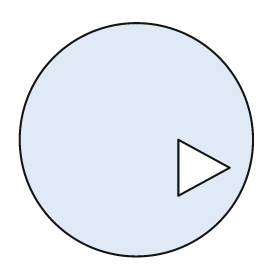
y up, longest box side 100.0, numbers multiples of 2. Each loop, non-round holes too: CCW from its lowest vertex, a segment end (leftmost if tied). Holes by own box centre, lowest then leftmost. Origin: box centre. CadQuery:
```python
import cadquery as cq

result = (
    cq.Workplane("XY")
    .moveTo(0.0, 0.0)
    .circle(50.0)
    .moveTo(18.0, -24.0)
    .lineTo(40.0, -12.0)
    .lineTo(18.0, 0.0)
    .close()
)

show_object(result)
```